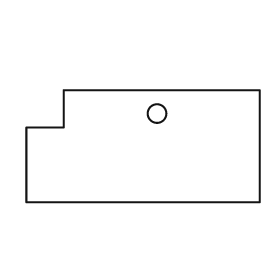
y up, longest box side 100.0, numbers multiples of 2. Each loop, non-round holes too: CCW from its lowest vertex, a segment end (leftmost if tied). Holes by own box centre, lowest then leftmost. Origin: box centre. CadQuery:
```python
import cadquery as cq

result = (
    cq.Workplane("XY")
    .moveTo(-50.0, -24.0)
    .lineTo(50.0, -24.0)
    .lineTo(50.0, 24.0)
    .lineTo(-34.0, 24.0)
    .lineTo(-34.0, 8.0)
    .lineTo(-50.0, 8.0)
    .close()
    .moveTo(6.0, 14.0)
    .circle(4.0)
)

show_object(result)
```